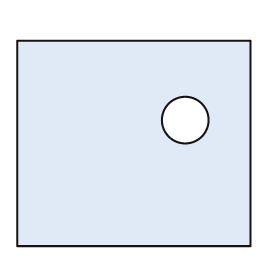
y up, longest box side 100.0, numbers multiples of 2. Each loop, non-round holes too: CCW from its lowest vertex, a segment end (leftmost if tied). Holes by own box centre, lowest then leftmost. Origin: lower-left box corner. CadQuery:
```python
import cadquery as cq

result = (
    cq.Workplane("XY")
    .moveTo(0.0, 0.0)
    .lineTo(100.0, 0.0)
    .lineTo(100.0, 88.0)
    .lineTo(0.0, 88.0)
    .close()
    .moveTo(72.0, 54.0)
    .circle(10.0)
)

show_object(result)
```